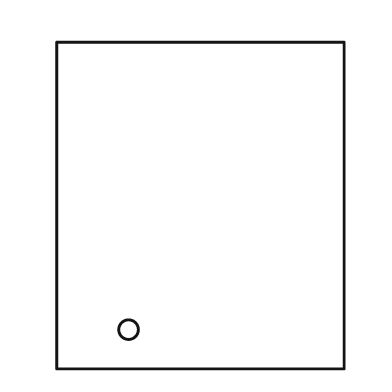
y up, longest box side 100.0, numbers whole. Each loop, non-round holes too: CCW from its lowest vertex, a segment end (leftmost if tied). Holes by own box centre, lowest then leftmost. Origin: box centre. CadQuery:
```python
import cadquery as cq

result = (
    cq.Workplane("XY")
    .moveTo(-44.0, -50.0)
    .lineTo(44.0, -50.0)
    .lineTo(44.0, 50.0)
    .lineTo(-44.0, 50.0)
    .close()
    .moveTo(-22.0, -38.0)
    .circle(3.0)
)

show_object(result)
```